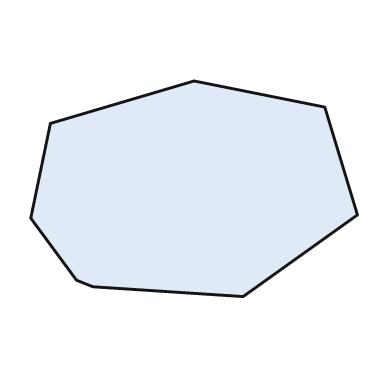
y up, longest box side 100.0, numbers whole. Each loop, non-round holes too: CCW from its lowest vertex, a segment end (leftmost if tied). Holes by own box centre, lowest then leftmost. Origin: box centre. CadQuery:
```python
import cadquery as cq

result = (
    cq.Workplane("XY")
    .moveTo(15.0, -33.0)
    .lineTo(50.0, -8.0)
    .lineTo(40.0, 25.0)
    .lineTo(0.0, 33.0)
    .lineTo(-44.0, 20.0)
    .lineTo(-50.0, -9.0)
    .lineTo(-36.0, -28.0)
    .lineTo(-31.0, -30.0)
    .close()
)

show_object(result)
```